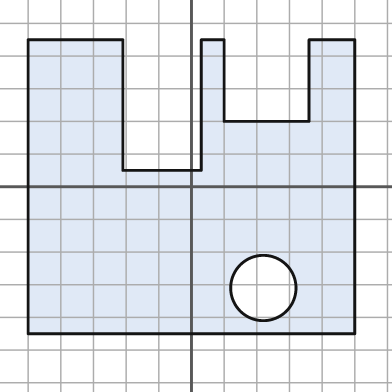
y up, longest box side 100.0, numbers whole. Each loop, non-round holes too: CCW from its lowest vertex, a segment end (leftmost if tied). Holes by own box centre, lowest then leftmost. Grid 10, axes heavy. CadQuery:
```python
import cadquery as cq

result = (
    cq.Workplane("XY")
    .moveTo(-50.0, -45.0)
    .lineTo(50.0, -45.0)
    .lineTo(50.0, 45.0)
    .lineTo(36.0, 45.0)
    .lineTo(36.0, 20.0)
    .lineTo(10.0, 20.0)
    .lineTo(10.0, 45.0)
    .lineTo(3.0, 45.0)
    .lineTo(3.0, 5.0)
    .lineTo(-21.0, 5.0)
    .lineTo(-21.0, 45.0)
    .lineTo(-50.0, 45.0)
    .close()
    .moveTo(22.0, -31.0)
    .circle(10.0)
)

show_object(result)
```